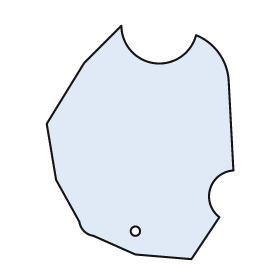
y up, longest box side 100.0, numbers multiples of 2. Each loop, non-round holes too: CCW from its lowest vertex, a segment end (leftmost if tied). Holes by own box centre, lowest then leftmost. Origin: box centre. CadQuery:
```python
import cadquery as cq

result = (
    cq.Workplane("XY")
    .moveTo(22.0, -50.0)
    .lineTo(34.0, -32.0)
    .threePointArc((30.0, -20.0), (40.0, -12.0))
    .lineTo(38.0, 26.0)
    .threePointArc((34.0, 38.0), (24.0, 46.0))
    .threePointArc((6.0, 34.0), (-8.0, 50.0))
    .lineTo(-24.0, 34.0)
    .lineTo(-40.0, 8.0)
    .lineTo(-36.0, -16.0)
    .lineTo(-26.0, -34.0)
    .threePointArc((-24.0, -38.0), (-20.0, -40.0))
    .lineTo(-2.0, -48.0)
    .close()
    .moveTo(-2.0, -38.0)
    .circle(2.0)
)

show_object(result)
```